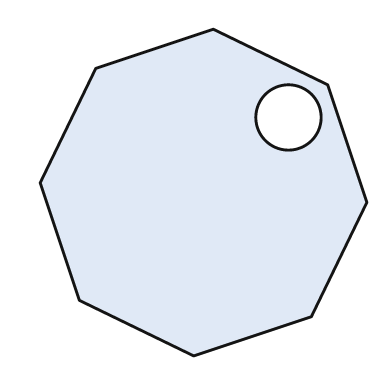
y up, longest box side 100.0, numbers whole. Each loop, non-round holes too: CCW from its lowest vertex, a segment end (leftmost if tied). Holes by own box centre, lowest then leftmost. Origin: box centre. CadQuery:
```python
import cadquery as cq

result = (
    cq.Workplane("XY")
    .moveTo(-3.0, -50.0)
    .lineTo(33.0, -38.0)
    .lineTo(50.0, -3.0)
    .lineTo(38.0, 33.0)
    .lineTo(3.0, 50.0)
    .lineTo(-33.0, 38.0)
    .lineTo(-50.0, 3.0)
    .lineTo(-38.0, -33.0)
    .close()
    .moveTo(26.0, 23.0)
    .circle(10.0)
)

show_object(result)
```